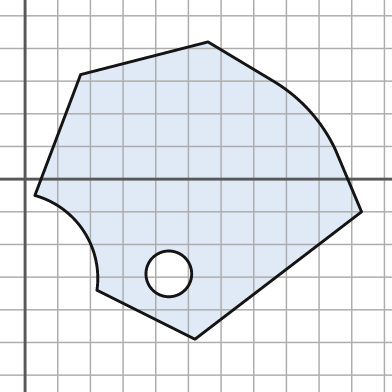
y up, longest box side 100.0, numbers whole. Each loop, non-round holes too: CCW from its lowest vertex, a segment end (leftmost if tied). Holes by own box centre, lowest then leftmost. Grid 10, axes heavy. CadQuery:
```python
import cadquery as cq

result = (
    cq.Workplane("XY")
    .moveTo(52.0, -49.0)
    .lineTo(103.0, -10.0)
    .lineTo(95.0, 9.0)
    .threePointArc((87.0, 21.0), (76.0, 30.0))
    .lineTo(56.0, 42.0)
    .lineTo(17.0, 32.0)
    .lineTo(3.0, -5.0)
    .threePointArc((18.0, -16.0), (22.0, -34.0))
    .close()
    .moveTo(44.0, -29.0)
    .circle(7.0)
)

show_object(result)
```